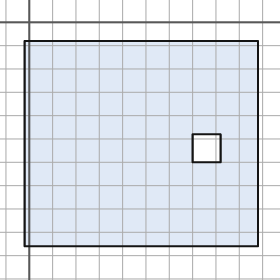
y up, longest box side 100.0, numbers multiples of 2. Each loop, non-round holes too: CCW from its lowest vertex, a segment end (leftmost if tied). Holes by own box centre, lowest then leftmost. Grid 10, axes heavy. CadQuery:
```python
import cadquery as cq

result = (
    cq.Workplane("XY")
    .moveTo(-2.0, -96.0)
    .lineTo(98.0, -96.0)
    .lineTo(98.0, -8.0)
    .lineTo(-2.0, -8.0)
    .close()
    .moveTo(70.0, -60.0)
    .lineTo(82.0, -60.0)
    .lineTo(82.0, -48.0)
    .lineTo(70.0, -48.0)
    .close()
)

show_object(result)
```